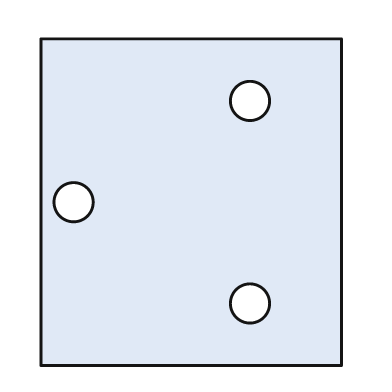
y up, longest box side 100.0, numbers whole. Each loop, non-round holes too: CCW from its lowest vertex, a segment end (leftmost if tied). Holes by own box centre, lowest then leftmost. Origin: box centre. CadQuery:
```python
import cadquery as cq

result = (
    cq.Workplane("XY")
    .moveTo(-46.0, -50.0)
    .lineTo(46.0, -50.0)
    .lineTo(46.0, 50.0)
    .lineTo(-46.0, 50.0)
    .close()
    .moveTo(18.0, -31.0)
    .circle(6.0)
    .moveTo(-36.0, 0.0)
    .circle(6.0)
    .moveTo(18.0, 31.0)
    .circle(6.0)
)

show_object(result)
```